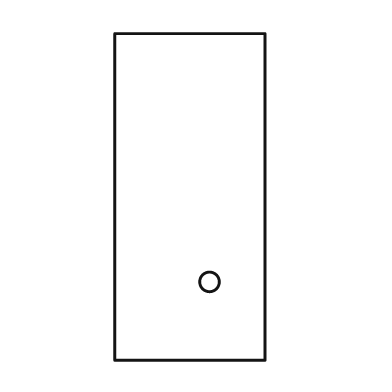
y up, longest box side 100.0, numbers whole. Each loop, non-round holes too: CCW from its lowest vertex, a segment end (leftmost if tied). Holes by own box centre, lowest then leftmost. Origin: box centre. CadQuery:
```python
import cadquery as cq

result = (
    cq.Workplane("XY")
    .moveTo(-23.0, -50.0)
    .lineTo(23.0, -50.0)
    .lineTo(23.0, 50.0)
    .lineTo(-23.0, 50.0)
    .close()
    .moveTo(6.0, -26.0)
    .circle(3.0)
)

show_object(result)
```